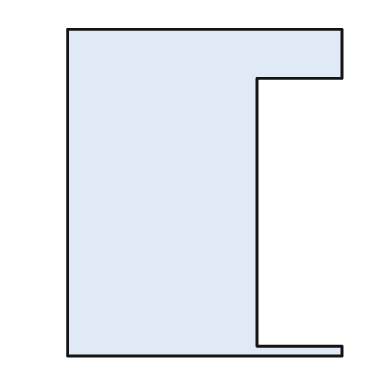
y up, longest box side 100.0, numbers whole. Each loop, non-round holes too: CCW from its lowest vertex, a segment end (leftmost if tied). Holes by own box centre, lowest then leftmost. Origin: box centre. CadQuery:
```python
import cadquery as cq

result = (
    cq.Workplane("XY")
    .moveTo(-42.0, -50.0)
    .lineTo(42.0, -50.0)
    .lineTo(42.0, -47.0)
    .lineTo(16.0, -47.0)
    .lineTo(16.0, 35.0)
    .lineTo(42.0, 35.0)
    .lineTo(42.0, 50.0)
    .lineTo(-42.0, 50.0)
    .close()
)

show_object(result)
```